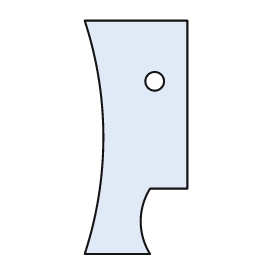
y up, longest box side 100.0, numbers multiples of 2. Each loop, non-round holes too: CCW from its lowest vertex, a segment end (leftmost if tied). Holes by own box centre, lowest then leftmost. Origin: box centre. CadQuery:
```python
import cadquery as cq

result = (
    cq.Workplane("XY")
    .moveTo(-22.0, -50.0)
    .lineTo(6.0, -50.0)
    .threePointArc((2.0, -36.0), (6.0, -22.0))
    .lineTo(22.0, -22.0)
    .lineTo(22.0, 50.0)
    .lineTo(-22.0, 50.0)
    .threePointArc((-14.0, 0.0), (-22.0, -50.0))
    .close()
    .moveTo(8.0, 24.0)
    .circle(4.0)
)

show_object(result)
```